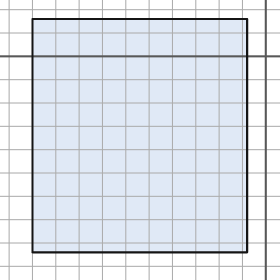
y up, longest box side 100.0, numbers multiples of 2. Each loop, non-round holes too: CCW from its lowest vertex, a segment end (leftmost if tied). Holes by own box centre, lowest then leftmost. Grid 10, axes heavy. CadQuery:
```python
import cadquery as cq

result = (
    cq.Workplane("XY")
    .moveTo(-100.0, -84.0)
    .lineTo(-8.0, -84.0)
    .lineTo(-8.0, 16.0)
    .lineTo(-100.0, 16.0)
    .close()
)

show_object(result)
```